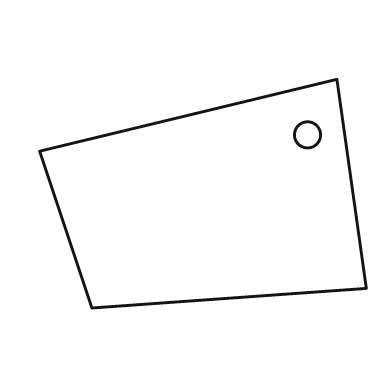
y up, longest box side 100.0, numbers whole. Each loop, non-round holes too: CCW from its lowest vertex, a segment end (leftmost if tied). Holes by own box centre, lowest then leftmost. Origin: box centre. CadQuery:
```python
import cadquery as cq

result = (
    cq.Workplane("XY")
    .moveTo(-34.0, -35.0)
    .lineTo(50.0, -29.0)
    .lineTo(41.0, 35.0)
    .lineTo(-50.0, 13.0)
    .close()
    .moveTo(32.0, 18.0)
    .circle(4.0)
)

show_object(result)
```